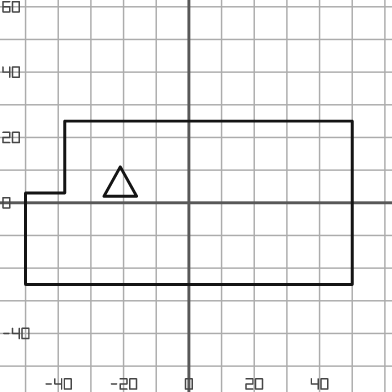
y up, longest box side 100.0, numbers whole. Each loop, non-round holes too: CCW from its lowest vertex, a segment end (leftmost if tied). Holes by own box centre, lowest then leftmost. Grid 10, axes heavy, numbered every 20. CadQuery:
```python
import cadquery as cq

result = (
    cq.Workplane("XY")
    .moveTo(-50.0, -25.0)
    .lineTo(50.0, -25.0)
    .lineTo(50.0, 25.0)
    .lineTo(-38.0, 25.0)
    .lineTo(-38.0, 3.0)
    .lineTo(-50.0, 3.0)
    .close()
    .moveTo(-26.0, 2.0)
    .lineTo(-16.0, 2.0)
    .lineTo(-21.0, 11.0)
    .close()
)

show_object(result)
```